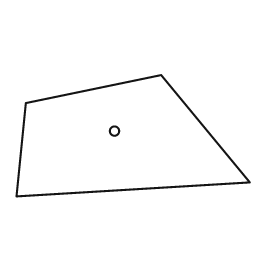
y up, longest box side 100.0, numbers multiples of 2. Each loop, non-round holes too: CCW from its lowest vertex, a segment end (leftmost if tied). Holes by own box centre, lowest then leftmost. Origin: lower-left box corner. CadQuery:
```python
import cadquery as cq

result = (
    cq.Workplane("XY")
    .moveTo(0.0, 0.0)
    .lineTo(100.0, 6.0)
    .lineTo(62.0, 52.0)
    .lineTo(4.0, 40.0)
    .close()
    .moveTo(42.0, 28.0)
    .circle(2.0)
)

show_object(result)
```